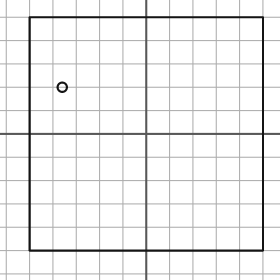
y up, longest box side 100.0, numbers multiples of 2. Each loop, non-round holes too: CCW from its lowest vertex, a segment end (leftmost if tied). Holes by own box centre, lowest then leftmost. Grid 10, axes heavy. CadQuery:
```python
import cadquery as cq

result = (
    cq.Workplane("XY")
    .moveTo(-50.0, -50.0)
    .lineTo(50.0, -50.0)
    .lineTo(50.0, 50.0)
    .lineTo(-50.0, 50.0)
    .close()
    .moveTo(-36.0, 20.0)
    .circle(2.0)
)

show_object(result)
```